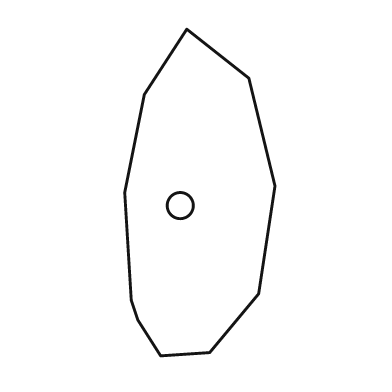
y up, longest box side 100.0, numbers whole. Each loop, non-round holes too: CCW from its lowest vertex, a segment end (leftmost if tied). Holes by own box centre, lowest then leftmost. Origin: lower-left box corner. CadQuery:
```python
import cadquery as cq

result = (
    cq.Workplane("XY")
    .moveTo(11.0, 0.0)
    .lineTo(26.0, 1.0)
    .lineTo(41.0, 19.0)
    .lineTo(46.0, 52.0)
    .lineTo(38.0, 85.0)
    .lineTo(19.0, 100.0)
    .lineTo(6.0, 80.0)
    .lineTo(0.0, 50.0)
    .lineTo(2.0, 17.0)
    .lineTo(4.0, 11.0)
    .close()
    .moveTo(17.0, 46.0)
    .circle(4.0)
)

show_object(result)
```